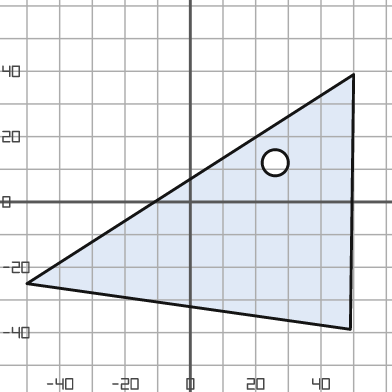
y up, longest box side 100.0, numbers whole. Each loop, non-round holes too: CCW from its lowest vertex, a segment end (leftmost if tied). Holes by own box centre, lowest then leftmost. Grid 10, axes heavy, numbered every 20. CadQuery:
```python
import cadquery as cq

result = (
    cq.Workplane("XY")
    .moveTo(49.0, -39.0)
    .lineTo(50.0, 39.0)
    .lineTo(-50.0, -25.0)
    .close()
    .moveTo(26.0, 12.0)
    .circle(4.0)
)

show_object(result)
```